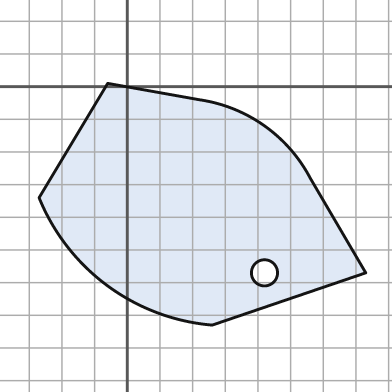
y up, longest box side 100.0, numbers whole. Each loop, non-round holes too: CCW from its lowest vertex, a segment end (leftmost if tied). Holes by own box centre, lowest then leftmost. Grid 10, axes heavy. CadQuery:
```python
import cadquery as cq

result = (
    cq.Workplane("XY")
    .moveTo(26.0, -73.0)
    .lineTo(73.0, -57.0)
    .lineTo(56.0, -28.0)
    .threePointArc((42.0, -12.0), (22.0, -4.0))
    .lineTo(-6.0, 1.0)
    .lineTo(-27.0, -34.0)
    .threePointArc((-6.0, -61.0), (26.0, -73.0))
    .close()
    .moveTo(42.0, -57.0)
    .circle(4.0)
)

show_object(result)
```